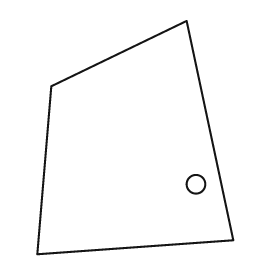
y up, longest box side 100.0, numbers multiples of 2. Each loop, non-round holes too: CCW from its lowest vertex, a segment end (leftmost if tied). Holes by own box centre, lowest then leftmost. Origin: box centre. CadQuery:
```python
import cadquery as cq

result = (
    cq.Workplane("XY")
    .moveTo(-42.0, -50.0)
    .lineTo(42.0, -44.0)
    .lineTo(22.0, 50.0)
    .lineTo(-36.0, 22.0)
    .close()
    .moveTo(26.0, -20.0)
    .circle(4.0)
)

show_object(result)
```